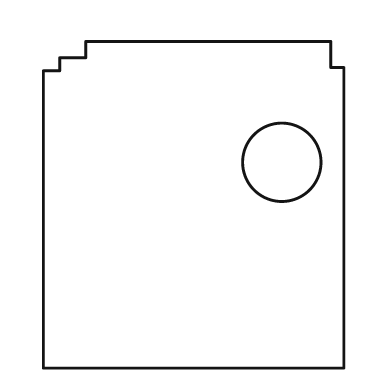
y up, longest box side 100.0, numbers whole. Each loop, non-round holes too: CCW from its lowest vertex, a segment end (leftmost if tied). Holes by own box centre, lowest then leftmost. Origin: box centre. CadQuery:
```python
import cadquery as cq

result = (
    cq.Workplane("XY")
    .moveTo(-46.0, -50.0)
    .lineTo(46.0, -50.0)
    .lineTo(46.0, 42.0)
    .lineTo(42.0, 42.0)
    .lineTo(42.0, 50.0)
    .lineTo(-33.0, 50.0)
    .lineTo(-33.0, 45.0)
    .lineTo(-41.0, 45.0)
    .lineTo(-41.0, 41.0)
    .lineTo(-46.0, 41.0)
    .close()
    .moveTo(27.0, 13.0)
    .circle(12.0)
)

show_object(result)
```